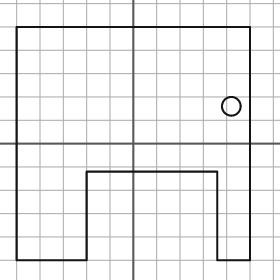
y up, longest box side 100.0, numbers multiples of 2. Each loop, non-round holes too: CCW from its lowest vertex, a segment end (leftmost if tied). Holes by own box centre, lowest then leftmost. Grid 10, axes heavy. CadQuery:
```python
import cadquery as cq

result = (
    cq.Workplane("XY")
    .moveTo(-50.0, -50.0)
    .lineTo(-20.0, -50.0)
    .lineTo(-20.0, -12.0)
    .lineTo(36.0, -12.0)
    .lineTo(36.0, -50.0)
    .lineTo(50.0, -50.0)
    .lineTo(50.0, 50.0)
    .lineTo(-50.0, 50.0)
    .close()
    .moveTo(42.0, 16.0)
    .circle(4.0)
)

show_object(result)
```